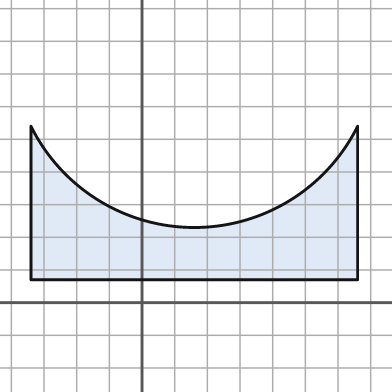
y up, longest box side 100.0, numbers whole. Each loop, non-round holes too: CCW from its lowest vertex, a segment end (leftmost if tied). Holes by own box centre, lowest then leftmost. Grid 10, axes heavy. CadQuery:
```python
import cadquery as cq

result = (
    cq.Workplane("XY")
    .moveTo(-34.0, 7.0)
    .lineTo(66.0, 7.0)
    .lineTo(66.0, 54.0)
    .threePointArc((16.0, 23.0), (-34.0, 54.0))
    .close()
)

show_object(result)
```